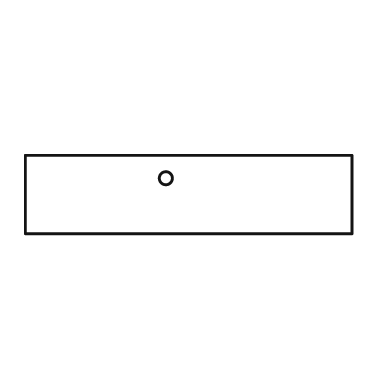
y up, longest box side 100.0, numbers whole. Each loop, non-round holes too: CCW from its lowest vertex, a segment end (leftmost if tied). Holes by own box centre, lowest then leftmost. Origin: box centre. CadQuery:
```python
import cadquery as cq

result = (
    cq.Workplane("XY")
    .moveTo(-50.0, -12.0)
    .lineTo(50.0, -12.0)
    .lineTo(50.0, 12.0)
    .lineTo(-50.0, 12.0)
    .close()
    .moveTo(-7.0, 5.0)
    .circle(2.0)
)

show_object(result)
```